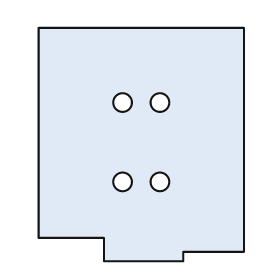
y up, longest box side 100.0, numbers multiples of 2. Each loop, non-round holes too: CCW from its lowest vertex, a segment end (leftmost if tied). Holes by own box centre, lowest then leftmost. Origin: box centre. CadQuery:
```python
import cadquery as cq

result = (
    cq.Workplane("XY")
    .moveTo(-16.0, -50.0)
    .lineTo(18.0, -50.0)
    .lineTo(18.0, -46.0)
    .lineTo(44.0, -46.0)
    .lineTo(44.0, 50.0)
    .lineTo(-44.0, 50.0)
    .lineTo(-44.0, -40.0)
    .lineTo(-16.0, -40.0)
    .close()
    .moveTo(-8.0, -16.0)
    .circle(4.0)
    .moveTo(8.0, -16.0)
    .circle(4.0)
    .moveTo(-8.0, 18.0)
    .circle(4.0)
    .moveTo(8.0, 18.0)
    .circle(4.0)
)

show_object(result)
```